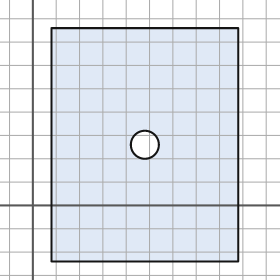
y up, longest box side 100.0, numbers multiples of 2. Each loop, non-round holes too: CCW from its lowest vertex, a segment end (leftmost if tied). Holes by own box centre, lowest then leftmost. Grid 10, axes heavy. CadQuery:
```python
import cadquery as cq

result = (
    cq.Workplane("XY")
    .moveTo(8.0, -24.0)
    .lineTo(88.0, -24.0)
    .lineTo(88.0, 76.0)
    .lineTo(8.0, 76.0)
    .close()
    .moveTo(48.0, 26.0)
    .circle(6.0)
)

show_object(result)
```